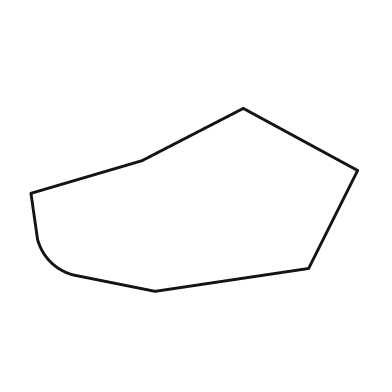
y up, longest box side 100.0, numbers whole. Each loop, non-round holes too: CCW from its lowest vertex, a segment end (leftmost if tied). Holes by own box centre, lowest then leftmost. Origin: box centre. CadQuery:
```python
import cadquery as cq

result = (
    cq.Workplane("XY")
    .moveTo(-12.0, -28.0)
    .lineTo(35.0, -21.0)
    .lineTo(50.0, 9.0)
    .lineTo(15.0, 28.0)
    .lineTo(-16.0, 12.0)
    .lineTo(-50.0, 2.0)
    .lineTo(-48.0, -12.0)
    .threePointArc((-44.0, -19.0), (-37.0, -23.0))
    .close()
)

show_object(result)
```